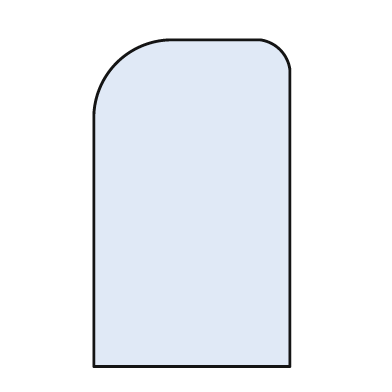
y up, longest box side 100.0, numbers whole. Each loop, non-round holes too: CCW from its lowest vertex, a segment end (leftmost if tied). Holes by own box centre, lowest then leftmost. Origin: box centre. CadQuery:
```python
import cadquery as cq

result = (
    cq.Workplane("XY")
    .moveTo(-30.0, -50.0)
    .lineTo(30.0, -50.0)
    .lineTo(30.0, 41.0)
    .threePointArc((27.0, 47.0), (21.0, 50.0))
    .lineTo(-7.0, 50.0)
    .threePointArc((-23.0, 43.0), (-30.0, 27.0))
    .close()
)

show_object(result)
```